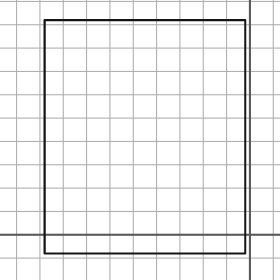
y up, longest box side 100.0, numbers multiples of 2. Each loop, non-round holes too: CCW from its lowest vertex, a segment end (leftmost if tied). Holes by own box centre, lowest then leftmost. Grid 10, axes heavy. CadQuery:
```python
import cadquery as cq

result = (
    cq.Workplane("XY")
    .moveTo(-88.0, -8.0)
    .lineTo(-2.0, -8.0)
    .lineTo(-2.0, 92.0)
    .lineTo(-88.0, 92.0)
    .close()
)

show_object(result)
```